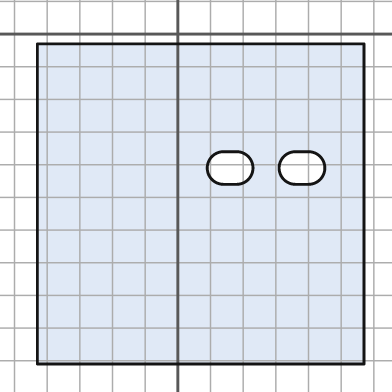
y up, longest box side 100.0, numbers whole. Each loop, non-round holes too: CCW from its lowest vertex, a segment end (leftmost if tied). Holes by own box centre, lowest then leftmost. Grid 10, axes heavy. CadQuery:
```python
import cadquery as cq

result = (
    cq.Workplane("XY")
    .moveTo(-43.0, -101.0)
    .lineTo(57.0, -101.0)
    .lineTo(57.0, -3.0)
    .lineTo(-43.0, -3.0)
    .close()
    .moveTo(14.0, -46.0)
    .lineTo(18.0, -46.0)
    .threePointArc((23.0, -41.0), (18.0, -36.0))
    .lineTo(14.0, -36.0)
    .threePointArc((9.0, -41.0), (14.0, -46.0))
    .close()
    .moveTo(36.0, -46.0)
    .lineTo(40.0, -46.0)
    .threePointArc((45.0, -41.0), (40.0, -36.0))
    .lineTo(36.0, -36.0)
    .threePointArc((31.0, -41.0), (36.0, -46.0))
    .close()
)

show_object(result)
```